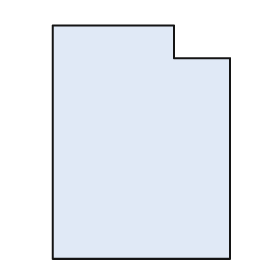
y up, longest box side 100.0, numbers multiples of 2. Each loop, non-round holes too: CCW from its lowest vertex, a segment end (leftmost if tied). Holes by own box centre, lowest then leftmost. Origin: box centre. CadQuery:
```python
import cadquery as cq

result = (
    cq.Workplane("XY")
    .moveTo(-38.0, -50.0)
    .lineTo(38.0, -50.0)
    .lineTo(38.0, 36.0)
    .lineTo(14.0, 36.0)
    .lineTo(14.0, 50.0)
    .lineTo(-38.0, 50.0)
    .close()
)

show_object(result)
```